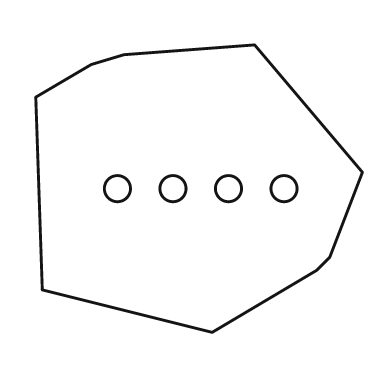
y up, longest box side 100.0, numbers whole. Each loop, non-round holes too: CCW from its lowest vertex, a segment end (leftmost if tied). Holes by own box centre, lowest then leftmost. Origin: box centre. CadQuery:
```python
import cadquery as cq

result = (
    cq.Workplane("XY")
    .moveTo(4.0, -44.0)
    .lineTo(36.0, -25.0)
    .lineTo(40.0, -21.0)
    .lineTo(50.0, 5.0)
    .lineTo(17.0, 44.0)
    .lineTo(-23.0, 41.0)
    .lineTo(-33.0, 38.0)
    .lineTo(-50.0, 28.0)
    .lineTo(-48.0, -31.0)
    .close()
    .moveTo(-25.0, 0.0)
    .circle(4.0)
    .moveTo(-8.0, 0.0)
    .circle(4.0)
    .moveTo(9.0, 0.0)
    .circle(4.0)
    .moveTo(26.0, 0.0)
    .circle(4.0)
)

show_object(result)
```